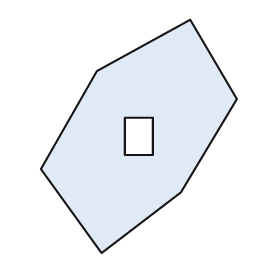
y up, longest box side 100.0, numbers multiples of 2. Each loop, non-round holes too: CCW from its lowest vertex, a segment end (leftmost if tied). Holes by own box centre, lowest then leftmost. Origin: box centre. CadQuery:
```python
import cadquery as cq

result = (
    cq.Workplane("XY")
    .moveTo(-16.0, -50.0)
    .lineTo(18.0, -24.0)
    .lineTo(42.0, 16.0)
    .lineTo(22.0, 50.0)
    .lineTo(-18.0, 28.0)
    .lineTo(-42.0, -14.0)
    .close()
    .moveTo(-6.0, -8.0)
    .lineTo(6.0, -8.0)
    .lineTo(6.0, 8.0)
    .lineTo(-6.0, 8.0)
    .close()
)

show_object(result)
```